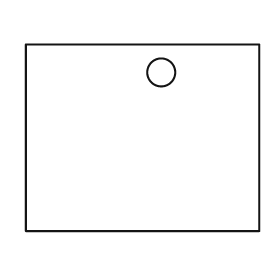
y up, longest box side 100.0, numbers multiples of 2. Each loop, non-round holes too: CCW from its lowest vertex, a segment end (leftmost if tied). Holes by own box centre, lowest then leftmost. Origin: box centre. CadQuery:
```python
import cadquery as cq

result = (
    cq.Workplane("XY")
    .moveTo(-50.0, -40.0)
    .lineTo(50.0, -40.0)
    .lineTo(50.0, 40.0)
    .lineTo(-50.0, 40.0)
    .close()
    .moveTo(8.0, 28.0)
    .circle(6.0)
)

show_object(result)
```